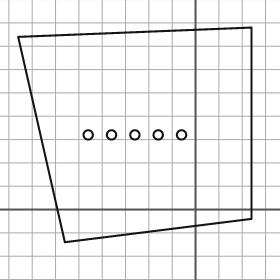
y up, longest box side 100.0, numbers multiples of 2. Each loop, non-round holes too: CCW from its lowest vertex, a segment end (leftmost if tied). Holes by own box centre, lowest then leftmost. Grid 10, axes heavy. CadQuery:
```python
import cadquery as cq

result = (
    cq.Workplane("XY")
    .moveTo(-56.0, -14.0)
    .lineTo(24.0, -4.0)
    .lineTo(24.0, 78.0)
    .lineTo(-76.0, 74.0)
    .close()
    .moveTo(-46.0, 32.0)
    .circle(2.0)
    .moveTo(-36.0, 32.0)
    .circle(2.0)
    .moveTo(-26.0, 32.0)
    .circle(2.0)
    .moveTo(-16.0, 32.0)
    .circle(2.0)
    .moveTo(-6.0, 32.0)
    .circle(2.0)
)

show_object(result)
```